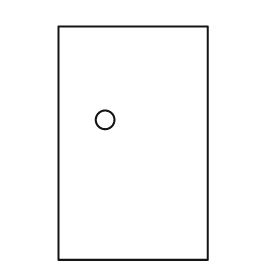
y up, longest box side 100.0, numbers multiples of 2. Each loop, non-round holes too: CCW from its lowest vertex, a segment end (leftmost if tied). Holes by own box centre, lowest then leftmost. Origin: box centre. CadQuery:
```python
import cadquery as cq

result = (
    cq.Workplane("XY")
    .moveTo(-32.0, -50.0)
    .lineTo(32.0, -50.0)
    .lineTo(32.0, 50.0)
    .lineTo(-32.0, 50.0)
    .close()
    .moveTo(-12.0, 10.0)
    .circle(4.0)
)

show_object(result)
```